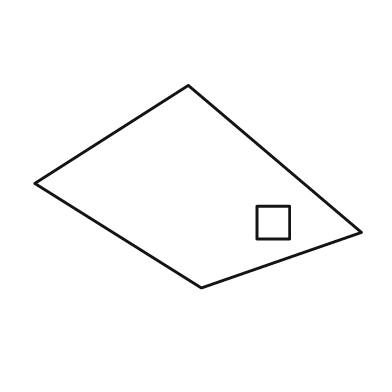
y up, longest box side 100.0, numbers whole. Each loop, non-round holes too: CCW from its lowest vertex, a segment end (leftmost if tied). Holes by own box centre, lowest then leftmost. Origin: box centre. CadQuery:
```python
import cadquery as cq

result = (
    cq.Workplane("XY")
    .moveTo(1.0, -31.0)
    .lineTo(50.0, -14.0)
    .lineTo(-3.0, 31.0)
    .lineTo(-50.0, 1.0)
    .close()
    .moveTo(18.0, -16.0)
    .lineTo(28.0, -16.0)
    .lineTo(28.0, -6.0)
    .lineTo(18.0, -6.0)
    .close()
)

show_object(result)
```